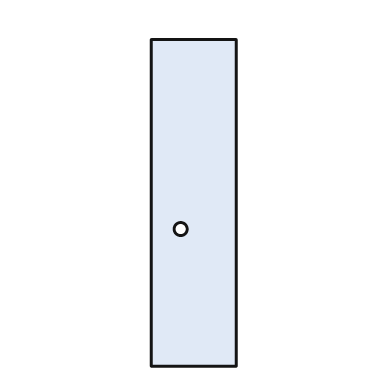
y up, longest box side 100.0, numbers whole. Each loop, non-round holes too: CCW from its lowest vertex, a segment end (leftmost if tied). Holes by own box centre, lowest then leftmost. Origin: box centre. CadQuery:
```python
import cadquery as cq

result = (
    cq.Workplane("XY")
    .moveTo(-13.0, -50.0)
    .lineTo(13.0, -50.0)
    .lineTo(13.0, 50.0)
    .lineTo(-13.0, 50.0)
    .close()
    .moveTo(-4.0, -8.0)
    .circle(2.0)
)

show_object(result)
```